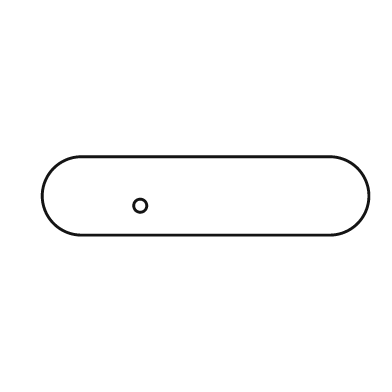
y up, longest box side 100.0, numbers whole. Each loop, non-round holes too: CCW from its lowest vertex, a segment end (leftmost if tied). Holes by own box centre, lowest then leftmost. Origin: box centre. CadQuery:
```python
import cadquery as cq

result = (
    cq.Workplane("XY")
    .moveTo(-38.0, -12.0)
    .lineTo(38.0, -12.0)
    .threePointArc((50.0, 0.0), (38.0, 12.0))
    .lineTo(-38.0, 12.0)
    .threePointArc((-50.0, 0.0), (-38.0, -12.0))
    .close()
    .moveTo(-20.0, -3.0)
    .circle(2.0)
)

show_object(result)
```